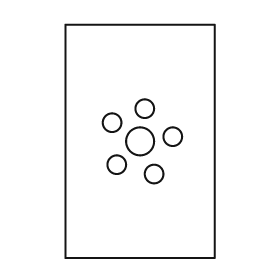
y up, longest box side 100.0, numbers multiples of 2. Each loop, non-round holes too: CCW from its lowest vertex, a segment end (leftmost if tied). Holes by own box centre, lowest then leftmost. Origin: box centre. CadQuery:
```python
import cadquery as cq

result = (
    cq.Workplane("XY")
    .moveTo(-32.0, -50.0)
    .lineTo(32.0, -50.0)
    .lineTo(32.0, 50.0)
    .lineTo(-32.0, 50.0)
    .close()
    .moveTo(6.0, -14.0)
    .circle(4.0)
    .moveTo(-10.0, -10.0)
    .circle(4.0)
    .moveTo(0.0, 0.0)
    .circle(6.0)
    .moveTo(14.0, 2.0)
    .circle(4.0)
    .moveTo(-12.0, 8.0)
    .circle(4.0)
    .moveTo(2.0, 14.0)
    .circle(4.0)
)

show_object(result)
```